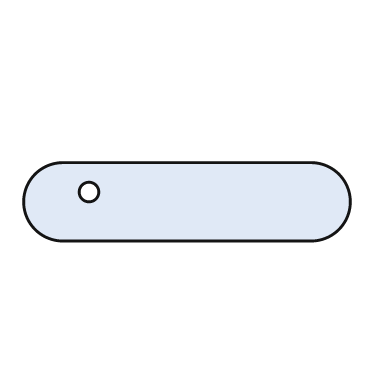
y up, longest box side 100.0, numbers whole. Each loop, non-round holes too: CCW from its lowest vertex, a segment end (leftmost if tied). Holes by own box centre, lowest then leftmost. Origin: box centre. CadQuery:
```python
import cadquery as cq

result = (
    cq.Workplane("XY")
    .moveTo(-38.0, -12.0)
    .lineTo(38.0, -12.0)
    .threePointArc((50.0, 0.0), (38.0, 12.0))
    .lineTo(-38.0, 12.0)
    .threePointArc((-50.0, 0.0), (-38.0, -12.0))
    .close()
    .moveTo(-30.0, 3.0)
    .circle(3.0)
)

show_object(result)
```